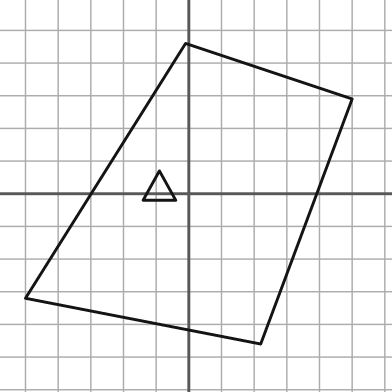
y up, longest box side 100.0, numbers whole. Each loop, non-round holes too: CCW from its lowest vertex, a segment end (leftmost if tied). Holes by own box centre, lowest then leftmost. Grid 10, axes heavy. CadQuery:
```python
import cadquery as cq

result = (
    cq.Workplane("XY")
    .moveTo(22.0, -46.0)
    .lineTo(50.0, 29.0)
    .lineTo(-1.0, 46.0)
    .lineTo(-50.0, -32.0)
    .close()
    .moveTo(-14.0, -2.0)
    .lineTo(-4.0, -2.0)
    .lineTo(-9.0, 7.0)
    .close()
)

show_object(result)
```